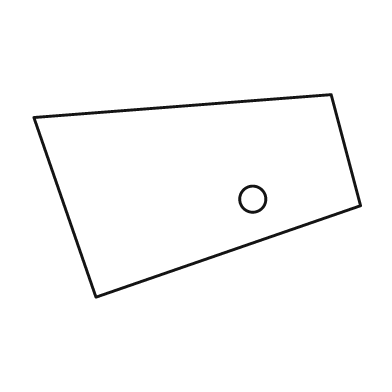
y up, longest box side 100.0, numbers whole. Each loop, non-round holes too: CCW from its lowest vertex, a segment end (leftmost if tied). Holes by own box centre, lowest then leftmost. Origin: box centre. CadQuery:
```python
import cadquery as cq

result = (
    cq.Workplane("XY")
    .moveTo(-31.0, -31.0)
    .lineTo(50.0, -3.0)
    .lineTo(41.0, 31.0)
    .lineTo(-50.0, 24.0)
    .close()
    .moveTo(17.0, -1.0)
    .circle(4.0)
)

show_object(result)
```